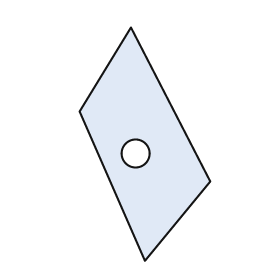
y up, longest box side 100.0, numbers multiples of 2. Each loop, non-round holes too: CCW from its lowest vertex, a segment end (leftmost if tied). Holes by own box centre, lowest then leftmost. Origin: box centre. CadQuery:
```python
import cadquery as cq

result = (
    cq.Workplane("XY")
    .moveTo(0.0, -50.0)
    .lineTo(28.0, -16.0)
    .lineTo(-6.0, 50.0)
    .lineTo(-28.0, 14.0)
    .close()
    .moveTo(-4.0, -4.0)
    .circle(6.0)
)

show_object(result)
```